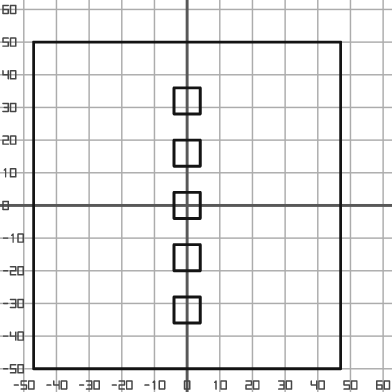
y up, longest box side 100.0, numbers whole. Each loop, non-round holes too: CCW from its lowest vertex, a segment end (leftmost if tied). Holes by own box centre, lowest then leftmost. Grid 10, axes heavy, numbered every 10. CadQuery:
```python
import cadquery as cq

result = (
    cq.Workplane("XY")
    .moveTo(-47.0, -50.0)
    .lineTo(47.0, -50.0)
    .lineTo(47.0, 50.0)
    .lineTo(-47.0, 50.0)
    .close()
    .moveTo(-4.0, -36.0)
    .lineTo(4.0, -36.0)
    .lineTo(4.0, -28.0)
    .lineTo(-4.0, -28.0)
    .close()
    .moveTo(-4.0, -20.0)
    .lineTo(4.0, -20.0)
    .lineTo(4.0, -12.0)
    .lineTo(-4.0, -12.0)
    .close()
    .moveTo(-4.0, -4.0)
    .lineTo(4.0, -4.0)
    .lineTo(4.0, 4.0)
    .lineTo(-4.0, 4.0)
    .close()
    .moveTo(-4.0, 12.0)
    .lineTo(4.0, 12.0)
    .lineTo(4.0, 20.0)
    .lineTo(-4.0, 20.0)
    .close()
    .moveTo(-4.0, 28.0)
    .lineTo(4.0, 28.0)
    .lineTo(4.0, 36.0)
    .lineTo(-4.0, 36.0)
    .close()
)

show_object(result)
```